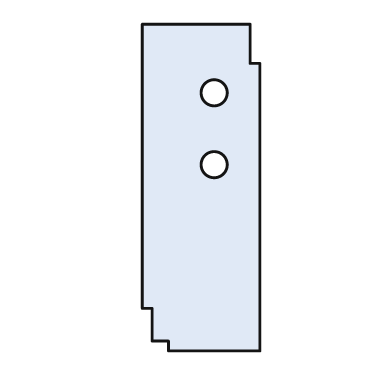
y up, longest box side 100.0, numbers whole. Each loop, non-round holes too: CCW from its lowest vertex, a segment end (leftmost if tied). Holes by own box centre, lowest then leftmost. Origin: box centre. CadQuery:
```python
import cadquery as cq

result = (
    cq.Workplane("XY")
    .moveTo(-10.0, -50.0)
    .lineTo(18.0, -50.0)
    .lineTo(18.0, 38.0)
    .lineTo(15.0, 38.0)
    .lineTo(15.0, 50.0)
    .lineTo(-18.0, 50.0)
    .lineTo(-18.0, -37.0)
    .lineTo(-15.0, -37.0)
    .lineTo(-15.0, -47.0)
    .lineTo(-10.0, -47.0)
    .close()
    .moveTo(4.0, 7.0)
    .circle(4.0)
    .moveTo(4.0, 29.0)
    .circle(4.0)
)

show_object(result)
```